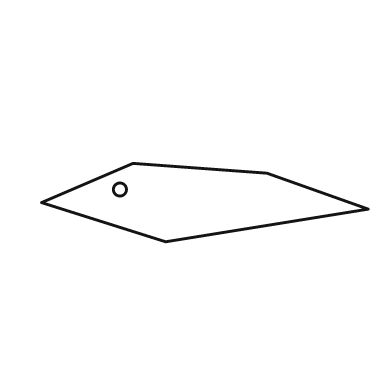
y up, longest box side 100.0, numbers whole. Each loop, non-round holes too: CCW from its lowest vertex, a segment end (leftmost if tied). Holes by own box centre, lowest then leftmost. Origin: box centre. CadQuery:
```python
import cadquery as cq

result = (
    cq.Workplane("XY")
    .moveTo(-12.0, -12.0)
    .lineTo(50.0, -2.0)
    .lineTo(19.0, 9.0)
    .lineTo(-22.0, 12.0)
    .lineTo(-50.0, 0.0)
    .close()
    .moveTo(-26.0, 4.0)
    .circle(2.0)
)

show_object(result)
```